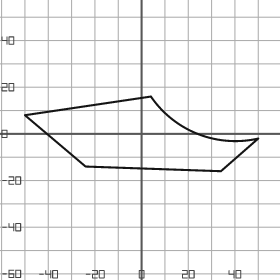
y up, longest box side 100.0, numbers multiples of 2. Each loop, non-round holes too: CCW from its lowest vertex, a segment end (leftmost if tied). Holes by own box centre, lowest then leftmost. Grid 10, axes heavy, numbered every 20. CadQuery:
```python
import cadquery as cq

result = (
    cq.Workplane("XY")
    .moveTo(34.0, -16.0)
    .lineTo(50.0, -2.0)
    .threePointArc((24.0, 0.0), (4.0, 16.0))
    .lineTo(-50.0, 8.0)
    .lineTo(-24.0, -14.0)
    .close()
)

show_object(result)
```